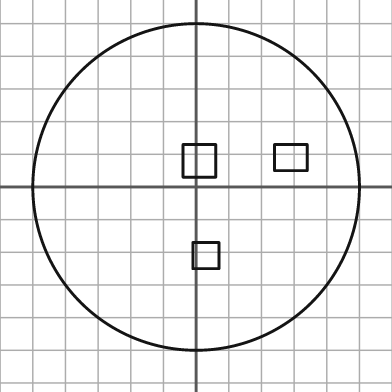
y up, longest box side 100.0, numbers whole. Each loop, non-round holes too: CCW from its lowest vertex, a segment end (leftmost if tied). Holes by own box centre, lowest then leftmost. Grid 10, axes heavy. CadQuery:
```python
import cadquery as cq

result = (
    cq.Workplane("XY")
    .moveTo(0.0, 0.0)
    .circle(50.0)
    .moveTo(-1.0, -25.0)
    .lineTo(7.0, -25.0)
    .lineTo(7.0, -17.0)
    .lineTo(-1.0, -17.0)
    .close()
    .moveTo(-4.0, 3.0)
    .lineTo(6.0, 3.0)
    .lineTo(6.0, 13.0)
    .lineTo(-4.0, 13.0)
    .close()
    .moveTo(24.0, 5.0)
    .lineTo(34.0, 5.0)
    .lineTo(34.0, 13.0)
    .lineTo(24.0, 13.0)
    .close()
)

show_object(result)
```